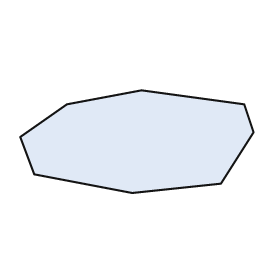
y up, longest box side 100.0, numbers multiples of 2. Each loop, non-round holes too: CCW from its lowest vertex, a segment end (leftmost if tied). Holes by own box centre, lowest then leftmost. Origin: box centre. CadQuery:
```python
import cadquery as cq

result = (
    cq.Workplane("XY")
    .moveTo(-2.0, -22.0)
    .lineTo(36.0, -18.0)
    .lineTo(50.0, 4.0)
    .lineTo(46.0, 16.0)
    .lineTo(2.0, 22.0)
    .lineTo(-30.0, 16.0)
    .lineTo(-50.0, 2.0)
    .lineTo(-44.0, -14.0)
    .close()
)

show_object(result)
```